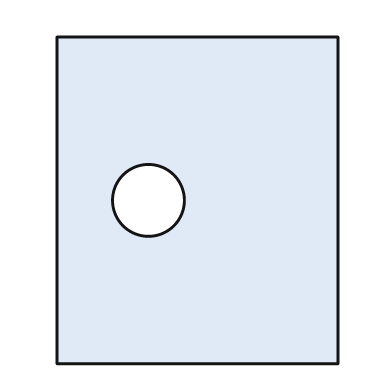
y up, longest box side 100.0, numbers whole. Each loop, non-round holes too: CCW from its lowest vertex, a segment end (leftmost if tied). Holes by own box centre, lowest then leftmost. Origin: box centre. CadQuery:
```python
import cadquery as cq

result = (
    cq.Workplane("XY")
    .moveTo(-43.0, -50.0)
    .lineTo(43.0, -50.0)
    .lineTo(43.0, 50.0)
    .lineTo(-43.0, 50.0)
    .close()
    .moveTo(-15.0, 0.0)
    .circle(11.0)
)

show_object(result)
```